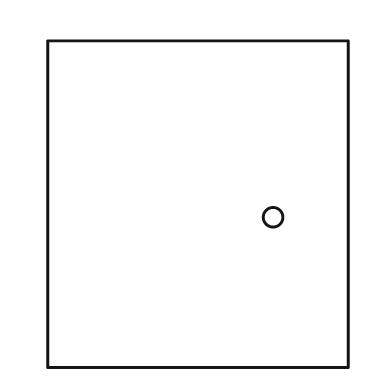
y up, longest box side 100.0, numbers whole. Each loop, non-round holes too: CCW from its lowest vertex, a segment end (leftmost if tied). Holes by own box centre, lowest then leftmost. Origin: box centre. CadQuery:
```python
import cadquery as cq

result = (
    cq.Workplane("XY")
    .moveTo(-46.0, -50.0)
    .lineTo(46.0, -50.0)
    .lineTo(46.0, 50.0)
    .lineTo(-46.0, 50.0)
    .close()
    .moveTo(23.0, -4.0)
    .circle(3.0)
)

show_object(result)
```